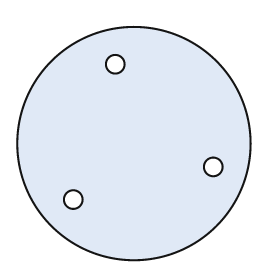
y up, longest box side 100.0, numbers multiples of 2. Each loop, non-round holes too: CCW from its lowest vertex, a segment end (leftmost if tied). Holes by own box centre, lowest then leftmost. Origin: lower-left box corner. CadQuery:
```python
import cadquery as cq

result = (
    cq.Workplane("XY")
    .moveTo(50.0, 50.0)
    .circle(50.0)
    .moveTo(24.0, 26.0)
    .circle(4.0)
    .moveTo(84.0, 40.0)
    .circle(4.0)
    .moveTo(42.0, 84.0)
    .circle(4.0)
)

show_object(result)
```